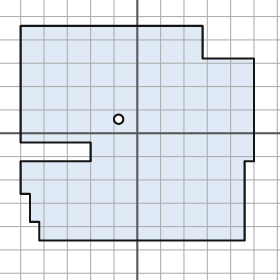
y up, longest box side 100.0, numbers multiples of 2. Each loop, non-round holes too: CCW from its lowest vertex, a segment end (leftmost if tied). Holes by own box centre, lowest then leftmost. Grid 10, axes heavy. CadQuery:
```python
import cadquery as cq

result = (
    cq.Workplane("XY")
    .moveTo(-42.0, -46.0)
    .lineTo(46.0, -46.0)
    .lineTo(46.0, -12.0)
    .lineTo(50.0, -12.0)
    .lineTo(50.0, 32.0)
    .lineTo(28.0, 32.0)
    .lineTo(28.0, 46.0)
    .lineTo(-50.0, 46.0)
    .lineTo(-50.0, -4.0)
    .lineTo(-20.0, -4.0)
    .lineTo(-20.0, -12.0)
    .lineTo(-50.0, -12.0)
    .lineTo(-50.0, -26.0)
    .lineTo(-46.0, -26.0)
    .lineTo(-46.0, -38.0)
    .lineTo(-42.0, -38.0)
    .close()
    .moveTo(-8.0, 6.0)
    .circle(2.0)
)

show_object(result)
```